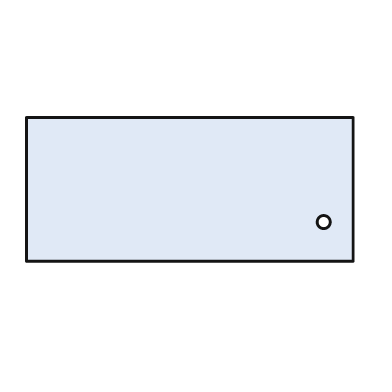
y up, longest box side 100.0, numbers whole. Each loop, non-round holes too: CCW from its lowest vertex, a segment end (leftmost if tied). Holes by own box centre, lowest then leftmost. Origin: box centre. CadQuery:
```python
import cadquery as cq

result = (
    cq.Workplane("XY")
    .moveTo(-50.0, -22.0)
    .lineTo(50.0, -22.0)
    .lineTo(50.0, 22.0)
    .lineTo(-50.0, 22.0)
    .close()
    .moveTo(41.0, -10.0)
    .circle(2.0)
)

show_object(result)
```